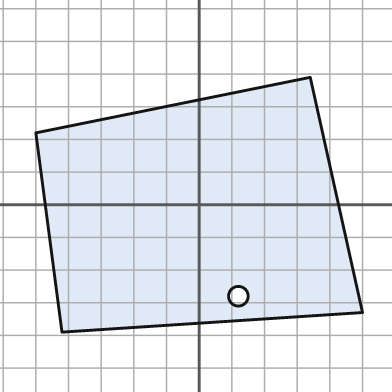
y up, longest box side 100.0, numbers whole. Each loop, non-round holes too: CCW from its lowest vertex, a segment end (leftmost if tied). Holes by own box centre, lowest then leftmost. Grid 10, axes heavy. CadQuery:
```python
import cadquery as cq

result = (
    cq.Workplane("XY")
    .moveTo(-42.0, -39.0)
    .lineTo(50.0, -33.0)
    .lineTo(34.0, 39.0)
    .lineTo(-50.0, 22.0)
    .close()
    .moveTo(12.0, -28.0)
    .circle(3.0)
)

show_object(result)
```